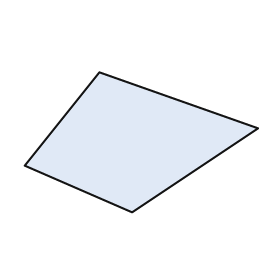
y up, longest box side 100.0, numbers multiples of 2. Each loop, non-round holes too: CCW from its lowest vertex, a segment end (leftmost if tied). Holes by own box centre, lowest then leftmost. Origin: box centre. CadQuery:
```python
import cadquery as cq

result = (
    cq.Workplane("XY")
    .moveTo(-4.0, -30.0)
    .lineTo(50.0, 6.0)
    .lineTo(-18.0, 30.0)
    .lineTo(-50.0, -10.0)
    .close()
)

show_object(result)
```